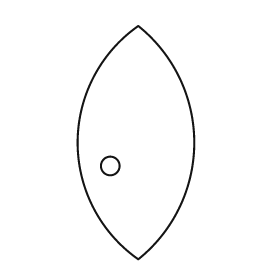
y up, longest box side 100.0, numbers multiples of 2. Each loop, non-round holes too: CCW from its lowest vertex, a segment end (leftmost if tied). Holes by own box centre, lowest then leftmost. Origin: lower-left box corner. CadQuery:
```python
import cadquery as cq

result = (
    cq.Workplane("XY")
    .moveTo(26.0, 0.0)
    .threePointArc((50.0, 50.0), (26.0, 100.0))
    .threePointArc((0.0, 50.0), (26.0, 0.0))
    .close()
    .moveTo(14.0, 40.0)
    .circle(4.0)
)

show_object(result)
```